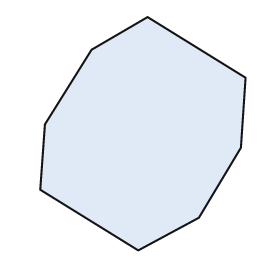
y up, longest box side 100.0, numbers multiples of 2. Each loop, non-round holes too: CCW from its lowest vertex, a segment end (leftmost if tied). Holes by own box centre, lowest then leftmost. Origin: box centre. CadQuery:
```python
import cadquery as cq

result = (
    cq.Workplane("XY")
    .moveTo(-2.0, -50.0)
    .lineTo(24.0, -36.0)
    .lineTo(42.0, -6.0)
    .lineTo(44.0, 24.0)
    .lineTo(2.0, 50.0)
    .lineTo(-22.0, 36.0)
    .lineTo(-42.0, 4.0)
    .lineTo(-44.0, -24.0)
    .close()
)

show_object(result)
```